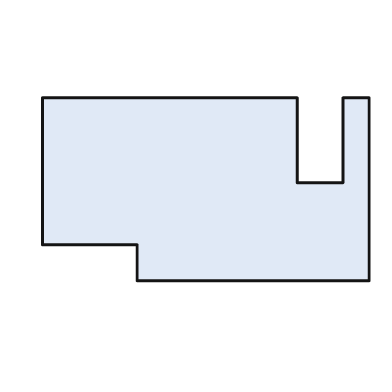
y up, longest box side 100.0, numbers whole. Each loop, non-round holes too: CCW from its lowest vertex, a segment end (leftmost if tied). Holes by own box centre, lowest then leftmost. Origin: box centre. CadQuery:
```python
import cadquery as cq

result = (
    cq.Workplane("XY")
    .moveTo(-21.0, -28.0)
    .lineTo(50.0, -28.0)
    .lineTo(50.0, 28.0)
    .lineTo(42.0, 28.0)
    .lineTo(42.0, 2.0)
    .lineTo(28.0, 2.0)
    .lineTo(28.0, 28.0)
    .lineTo(-50.0, 28.0)
    .lineTo(-50.0, -17.0)
    .lineTo(-21.0, -17.0)
    .close()
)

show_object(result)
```